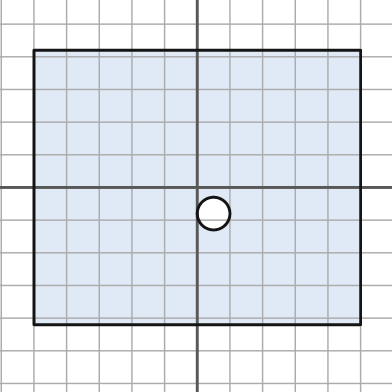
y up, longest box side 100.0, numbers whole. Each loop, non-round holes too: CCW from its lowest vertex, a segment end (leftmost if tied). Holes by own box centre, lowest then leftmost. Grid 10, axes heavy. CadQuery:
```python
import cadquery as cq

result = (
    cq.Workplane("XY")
    .moveTo(-50.0, -42.0)
    .lineTo(50.0, -42.0)
    .lineTo(50.0, 42.0)
    .lineTo(-50.0, 42.0)
    .close()
    .moveTo(5.0, -8.0)
    .circle(5.0)
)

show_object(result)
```